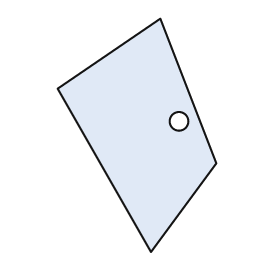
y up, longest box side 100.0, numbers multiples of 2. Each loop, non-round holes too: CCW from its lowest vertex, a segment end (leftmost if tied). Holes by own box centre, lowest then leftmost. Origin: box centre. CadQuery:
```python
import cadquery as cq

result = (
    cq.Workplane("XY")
    .moveTo(6.0, -50.0)
    .lineTo(34.0, -12.0)
    .lineTo(10.0, 50.0)
    .lineTo(-34.0, 20.0)
    .close()
    .moveTo(18.0, 6.0)
    .circle(4.0)
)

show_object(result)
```